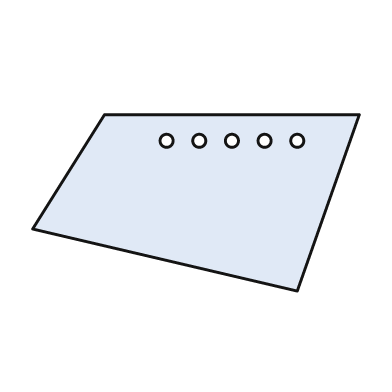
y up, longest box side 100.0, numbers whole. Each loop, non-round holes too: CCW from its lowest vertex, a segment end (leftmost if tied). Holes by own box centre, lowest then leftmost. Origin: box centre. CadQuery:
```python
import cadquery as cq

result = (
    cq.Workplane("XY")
    .moveTo(31.0, -27.0)
    .lineTo(50.0, 27.0)
    .lineTo(-28.0, 27.0)
    .lineTo(-50.0, -8.0)
    .close()
    .moveTo(-9.0, 19.0)
    .circle(2.0)
    .moveTo(1.0, 19.0)
    .circle(2.0)
    .moveTo(11.0, 19.0)
    .circle(2.0)
    .moveTo(21.0, 19.0)
    .circle(2.0)
    .moveTo(31.0, 19.0)
    .circle(2.0)
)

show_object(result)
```